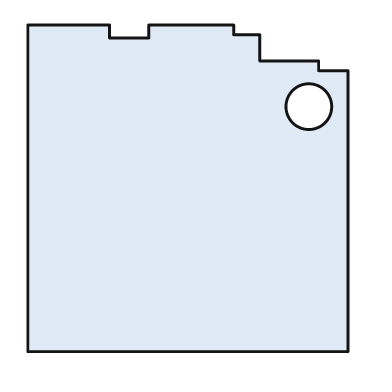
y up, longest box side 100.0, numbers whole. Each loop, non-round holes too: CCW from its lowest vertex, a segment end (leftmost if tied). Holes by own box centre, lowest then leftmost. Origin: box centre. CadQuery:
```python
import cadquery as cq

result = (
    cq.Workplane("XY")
    .moveTo(-49.0, -50.0)
    .lineTo(49.0, -50.0)
    .lineTo(49.0, 36.0)
    .lineTo(40.0, 36.0)
    .lineTo(40.0, 39.0)
    .lineTo(22.0, 39.0)
    .lineTo(22.0, 47.0)
    .lineTo(14.0, 47.0)
    .lineTo(14.0, 50.0)
    .lineTo(-12.0, 50.0)
    .lineTo(-12.0, 46.0)
    .lineTo(-24.0, 46.0)
    .lineTo(-24.0, 50.0)
    .lineTo(-49.0, 50.0)
    .close()
    .moveTo(37.0, 25.0)
    .circle(7.0)
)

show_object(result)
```